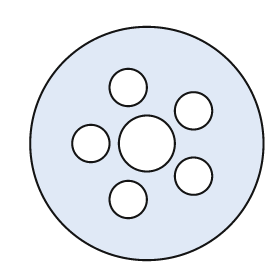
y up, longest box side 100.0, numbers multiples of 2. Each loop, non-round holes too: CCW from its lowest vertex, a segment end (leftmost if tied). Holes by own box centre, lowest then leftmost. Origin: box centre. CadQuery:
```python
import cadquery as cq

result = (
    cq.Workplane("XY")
    .moveTo(0.0, 0.0)
    .circle(50.0)
    .moveTo(-8.0, -24.0)
    .circle(8.0)
    .moveTo(20.0, -14.0)
    .circle(8.0)
    .moveTo(-24.0, 0.0)
    .circle(8.0)
    .moveTo(0.0, 0.0)
    .circle(12.0)
    .moveTo(20.0, 14.0)
    .circle(8.0)
    .moveTo(-8.0, 24.0)
    .circle(8.0)
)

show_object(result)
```